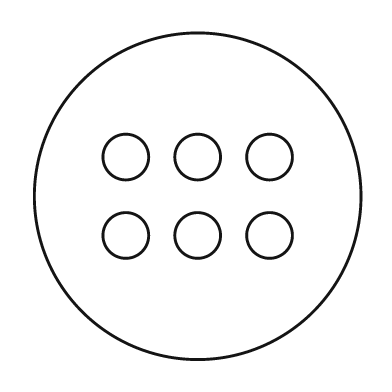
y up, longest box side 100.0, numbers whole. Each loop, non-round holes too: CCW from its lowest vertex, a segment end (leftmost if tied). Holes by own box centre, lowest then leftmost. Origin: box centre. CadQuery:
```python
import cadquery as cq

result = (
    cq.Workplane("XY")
    .moveTo(0.0, 0.0)
    .circle(50.0)
    .moveTo(-22.0, -12.0)
    .circle(7.0)
    .moveTo(0.0, -12.0)
    .circle(7.0)
    .moveTo(22.0, -12.0)
    .circle(7.0)
    .moveTo(-22.0, 12.0)
    .circle(7.0)
    .moveTo(0.0, 12.0)
    .circle(7.0)
    .moveTo(22.0, 12.0)
    .circle(7.0)
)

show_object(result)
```